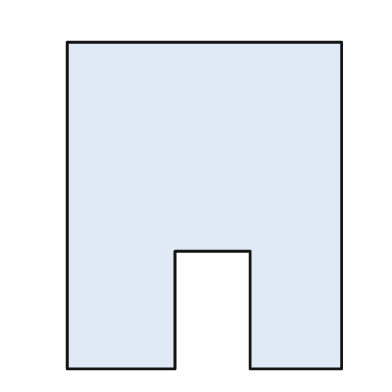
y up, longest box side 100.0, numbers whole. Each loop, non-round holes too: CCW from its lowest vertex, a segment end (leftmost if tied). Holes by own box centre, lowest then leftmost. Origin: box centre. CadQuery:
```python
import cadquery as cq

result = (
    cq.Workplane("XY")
    .moveTo(-42.0, -50.0)
    .lineTo(-9.0, -50.0)
    .lineTo(-9.0, -14.0)
    .lineTo(14.0, -14.0)
    .lineTo(14.0, -50.0)
    .lineTo(42.0, -50.0)
    .lineTo(42.0, 50.0)
    .lineTo(-42.0, 50.0)
    .close()
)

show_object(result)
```